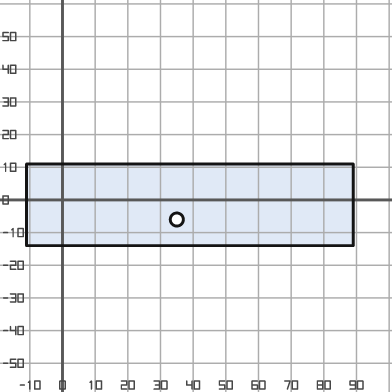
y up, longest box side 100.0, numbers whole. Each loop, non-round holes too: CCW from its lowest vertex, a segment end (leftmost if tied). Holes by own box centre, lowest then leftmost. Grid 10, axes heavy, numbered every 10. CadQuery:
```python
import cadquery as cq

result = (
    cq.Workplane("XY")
    .moveTo(-11.0, -14.0)
    .lineTo(89.0, -14.0)
    .lineTo(89.0, 11.0)
    .lineTo(-11.0, 11.0)
    .close()
    .moveTo(35.0, -6.0)
    .circle(2.0)
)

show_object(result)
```